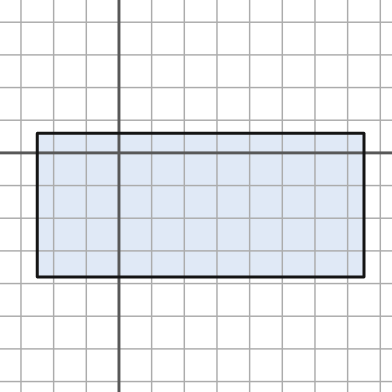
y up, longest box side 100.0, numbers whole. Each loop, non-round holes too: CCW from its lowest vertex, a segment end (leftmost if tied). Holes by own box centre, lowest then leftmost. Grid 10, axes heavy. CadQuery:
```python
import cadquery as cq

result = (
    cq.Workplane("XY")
    .moveTo(-25.0, -38.0)
    .lineTo(75.0, -38.0)
    .lineTo(75.0, 6.0)
    .lineTo(-25.0, 6.0)
    .close()
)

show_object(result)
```